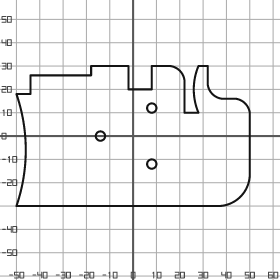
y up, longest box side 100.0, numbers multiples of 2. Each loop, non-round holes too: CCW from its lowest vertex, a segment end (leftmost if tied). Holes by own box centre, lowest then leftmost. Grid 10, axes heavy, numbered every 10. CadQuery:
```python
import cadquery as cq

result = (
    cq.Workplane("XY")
    .moveTo(-50.0, -30.0)
    .lineTo(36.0, -30.0)
    .threePointArc((46.0, -26.0), (50.0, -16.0))
    .lineTo(50.0, 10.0)
    .threePointArc((48.0, 14.0), (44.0, 16.0))
    .lineTo(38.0, 16.0)
    .threePointArc((34.0, 18.0), (32.0, 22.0))
    .lineTo(32.0, 30.0)
    .lineTo(28.0, 30.0)
    .threePointArc((26.0, 20.0), (28.0, 10.0))
    .lineTo(22.0, 10.0)
    .lineTo(22.0, 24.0)
    .threePointArc((20.0, 28.0), (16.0, 30.0))
    .lineTo(8.0, 30.0)
    .lineTo(8.0, 20.0)
    .lineTo(-2.0, 20.0)
    .lineTo(-2.0, 30.0)
    .lineTo(-18.0, 30.0)
    .lineTo(-18.0, 26.0)
    .lineTo(-44.0, 26.0)
    .lineTo(-44.0, 18.0)
    .lineTo(-50.0, 18.0)
    .threePointArc((-46.0, -6.0), (-50.0, -30.0))
    .close()
    .moveTo(8.0, -12.0)
    .circle(2.0)
    .moveTo(-14.0, 0.0)
    .circle(2.0)
    .moveTo(8.0, 12.0)
    .circle(2.0)
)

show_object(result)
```